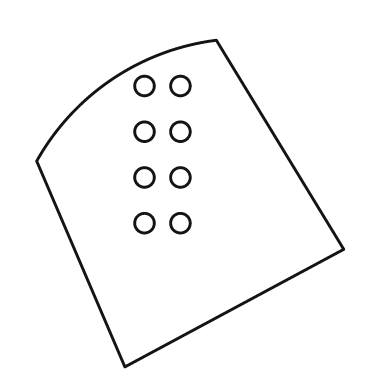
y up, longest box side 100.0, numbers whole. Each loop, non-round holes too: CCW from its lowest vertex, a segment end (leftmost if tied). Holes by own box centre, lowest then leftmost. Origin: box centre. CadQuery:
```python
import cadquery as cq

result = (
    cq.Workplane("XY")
    .moveTo(-20.0, -50.0)
    .lineTo(47.0, -14.0)
    .lineTo(8.0, 50.0)
    .threePointArc((-24.0, 38.0), (-47.0, 13.0))
    .close()
    .moveTo(-14.0, -6.0)
    .circle(3.0)
    .moveTo(-3.0, -6.0)
    .circle(3.0)
    .moveTo(-14.0, 8.0)
    .circle(3.0)
    .moveTo(-3.0, 8.0)
    .circle(3.0)
    .moveTo(-14.0, 22.0)
    .circle(3.0)
    .moveTo(-3.0, 22.0)
    .circle(3.0)
    .moveTo(-14.0, 36.0)
    .circle(3.0)
    .moveTo(-3.0, 36.0)
    .circle(3.0)
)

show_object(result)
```